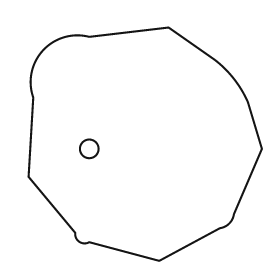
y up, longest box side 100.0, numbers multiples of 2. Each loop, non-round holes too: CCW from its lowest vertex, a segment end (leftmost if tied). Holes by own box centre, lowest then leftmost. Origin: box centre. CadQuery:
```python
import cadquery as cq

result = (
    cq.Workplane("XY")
    .moveTo(6.0, -50.0)
    .lineTo(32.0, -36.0)
    .threePointArc((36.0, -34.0), (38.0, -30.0))
    .lineTo(50.0, -2.0)
    .lineTo(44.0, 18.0)
    .threePointArc((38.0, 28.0), (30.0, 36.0))
    .lineTo(10.0, 50.0)
    .lineTo(-24.0, 46.0)
    .threePointArc((-44.0, 40.0), (-48.0, 20.0))
    .lineTo(-50.0, -14.0)
    .lineTo(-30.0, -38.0)
    .threePointArc((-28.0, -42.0), (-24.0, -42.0))
    .close()
    .moveTo(-24.0, -2.0)
    .circle(4.0)
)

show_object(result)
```